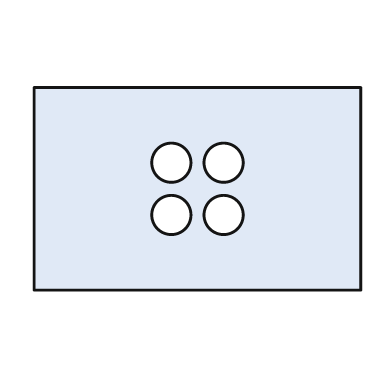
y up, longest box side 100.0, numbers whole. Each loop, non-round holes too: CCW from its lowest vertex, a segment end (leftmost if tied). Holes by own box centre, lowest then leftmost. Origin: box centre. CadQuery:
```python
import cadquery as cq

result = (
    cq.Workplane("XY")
    .moveTo(-50.0, -31.0)
    .lineTo(50.0, -31.0)
    .lineTo(50.0, 31.0)
    .lineTo(-50.0, 31.0)
    .close()
    .moveTo(-8.0, -8.0)
    .circle(6.0)
    .moveTo(8.0, -8.0)
    .circle(6.0)
    .moveTo(-8.0, 8.0)
    .circle(6.0)
    .moveTo(8.0, 8.0)
    .circle(6.0)
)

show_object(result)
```